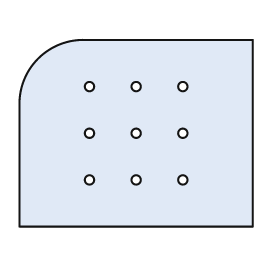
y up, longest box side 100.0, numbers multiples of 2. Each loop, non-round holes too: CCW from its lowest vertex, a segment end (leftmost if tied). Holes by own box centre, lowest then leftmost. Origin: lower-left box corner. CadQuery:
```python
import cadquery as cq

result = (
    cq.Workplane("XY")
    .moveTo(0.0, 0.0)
    .lineTo(100.0, 0.0)
    .lineTo(100.0, 80.0)
    .lineTo(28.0, 80.0)
    .threePointArc((8.0, 72.0), (0.0, 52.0))
    .close()
    .moveTo(30.0, 20.0)
    .circle(2.0)
    .moveTo(50.0, 20.0)
    .circle(2.0)
    .moveTo(70.0, 20.0)
    .circle(2.0)
    .moveTo(30.0, 40.0)
    .circle(2.0)
    .moveTo(50.0, 40.0)
    .circle(2.0)
    .moveTo(70.0, 40.0)
    .circle(2.0)
    .moveTo(30.0, 60.0)
    .circle(2.0)
    .moveTo(50.0, 60.0)
    .circle(2.0)
    .moveTo(70.0, 60.0)
    .circle(2.0)
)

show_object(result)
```